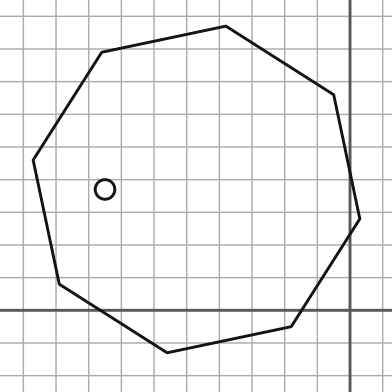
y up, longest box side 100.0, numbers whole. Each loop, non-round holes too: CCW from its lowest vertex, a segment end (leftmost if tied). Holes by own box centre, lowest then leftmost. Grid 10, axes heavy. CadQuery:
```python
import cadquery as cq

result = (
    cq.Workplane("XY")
    .moveTo(-56.0, -13.0)
    .lineTo(-18.0, -5.0)
    .lineTo(3.0, 28.0)
    .lineTo(-5.0, 66.0)
    .lineTo(-38.0, 87.0)
    .lineTo(-76.0, 79.0)
    .lineTo(-97.0, 46.0)
    .lineTo(-89.0, 8.0)
    .close()
    .moveTo(-75.0, 37.0)
    .circle(3.0)
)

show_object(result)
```